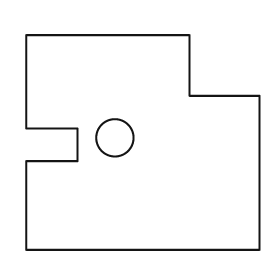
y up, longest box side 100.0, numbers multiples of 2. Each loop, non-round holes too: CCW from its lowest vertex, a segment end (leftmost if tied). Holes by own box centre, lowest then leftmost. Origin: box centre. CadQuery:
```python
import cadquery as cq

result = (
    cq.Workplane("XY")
    .moveTo(-50.0, -46.0)
    .lineTo(50.0, -46.0)
    .lineTo(50.0, 20.0)
    .lineTo(20.0, 20.0)
    .lineTo(20.0, 46.0)
    .lineTo(-50.0, 46.0)
    .lineTo(-50.0, 6.0)
    .lineTo(-28.0, 6.0)
    .lineTo(-28.0, -8.0)
    .lineTo(-50.0, -8.0)
    .close()
    .moveTo(-12.0, 2.0)
    .circle(8.0)
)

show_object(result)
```